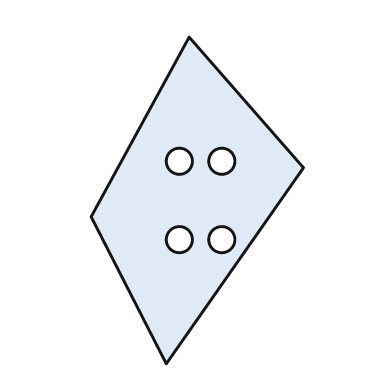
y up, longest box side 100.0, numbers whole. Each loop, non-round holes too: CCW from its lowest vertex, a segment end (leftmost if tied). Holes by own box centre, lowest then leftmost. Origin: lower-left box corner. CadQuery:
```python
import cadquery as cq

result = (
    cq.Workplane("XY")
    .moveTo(23.0, 0.0)
    .lineTo(65.0, 60.0)
    .lineTo(30.0, 100.0)
    .lineTo(0.0, 45.0)
    .close()
    .moveTo(27.0, 38.0)
    .circle(4.0)
    .moveTo(40.0, 38.0)
    .circle(4.0)
    .moveTo(27.0, 62.0)
    .circle(4.0)
    .moveTo(40.0, 62.0)
    .circle(4.0)
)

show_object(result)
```